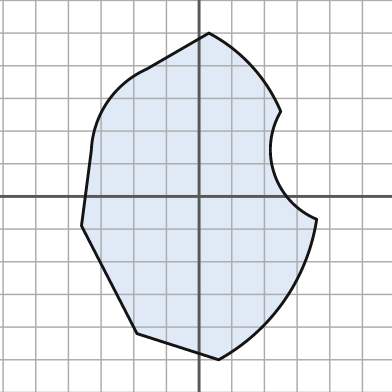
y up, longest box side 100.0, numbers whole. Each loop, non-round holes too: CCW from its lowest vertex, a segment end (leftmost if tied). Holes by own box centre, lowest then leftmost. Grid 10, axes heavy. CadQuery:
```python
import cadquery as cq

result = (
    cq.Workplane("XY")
    .moveTo(6.0, -50.0)
    .threePointArc((26.0, -32.0), (36.0, -7.0))
    .threePointArc((23.0, 7.0), (25.0, 26.0))
    .threePointArc((16.0, 40.0), (3.0, 50.0))
    .lineTo(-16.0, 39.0)
    .threePointArc((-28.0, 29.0), (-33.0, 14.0))
    .lineTo(-36.0, -9.0)
    .lineTo(-19.0, -42.0)
    .close()
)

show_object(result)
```